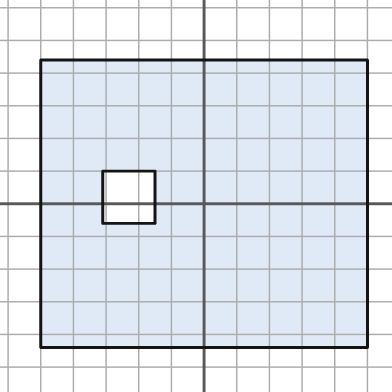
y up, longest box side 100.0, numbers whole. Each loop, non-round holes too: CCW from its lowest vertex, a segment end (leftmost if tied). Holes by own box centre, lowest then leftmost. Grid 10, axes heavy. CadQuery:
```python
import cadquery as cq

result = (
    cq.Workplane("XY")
    .moveTo(-50.0, -44.0)
    .lineTo(50.0, -44.0)
    .lineTo(50.0, 44.0)
    .lineTo(-50.0, 44.0)
    .close()
    .moveTo(-31.0, -6.0)
    .lineTo(-15.0, -6.0)
    .lineTo(-15.0, 10.0)
    .lineTo(-31.0, 10.0)
    .close()
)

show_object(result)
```